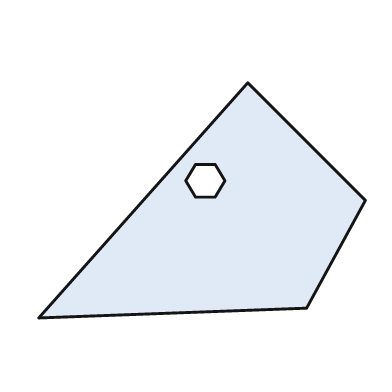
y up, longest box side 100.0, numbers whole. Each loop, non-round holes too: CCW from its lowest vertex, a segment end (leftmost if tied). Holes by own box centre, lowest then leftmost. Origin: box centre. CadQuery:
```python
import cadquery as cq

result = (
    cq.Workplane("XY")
    .moveTo(-50.0, -36.0)
    .lineTo(32.0, -33.0)
    .lineTo(50.0, 0.0)
    .lineTo(14.0, 36.0)
    .close()
    .moveTo(-2.0, 1.0)
    .lineTo(4.0, 1.0)
    .lineTo(7.0, 6.0)
    .lineTo(4.0, 11.0)
    .lineTo(-2.0, 11.0)
    .lineTo(-5.0, 6.0)
    .close()
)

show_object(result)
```